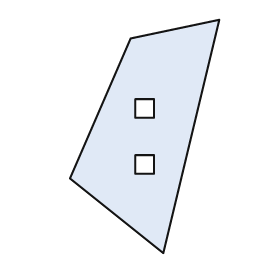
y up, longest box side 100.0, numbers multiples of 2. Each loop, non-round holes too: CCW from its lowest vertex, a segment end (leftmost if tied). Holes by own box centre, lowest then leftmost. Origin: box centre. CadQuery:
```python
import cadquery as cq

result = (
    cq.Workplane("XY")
    .moveTo(8.0, -50.0)
    .lineTo(32.0, 50.0)
    .lineTo(-6.0, 42.0)
    .lineTo(-32.0, -18.0)
    .close()
    .moveTo(-4.0, -16.0)
    .lineTo(4.0, -16.0)
    .lineTo(4.0, -8.0)
    .lineTo(-4.0, -8.0)
    .close()
    .moveTo(-4.0, 8.0)
    .lineTo(4.0, 8.0)
    .lineTo(4.0, 16.0)
    .lineTo(-4.0, 16.0)
    .close()
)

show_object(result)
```